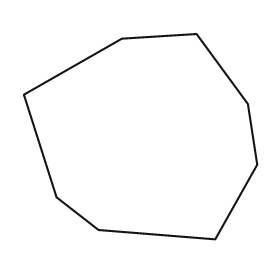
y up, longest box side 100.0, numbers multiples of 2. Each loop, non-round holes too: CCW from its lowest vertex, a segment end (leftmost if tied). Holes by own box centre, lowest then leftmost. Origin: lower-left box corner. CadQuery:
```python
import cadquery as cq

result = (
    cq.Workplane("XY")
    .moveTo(82.0, 0.0)
    .lineTo(100.0, 32.0)
    .lineTo(96.0, 58.0)
    .lineTo(74.0, 88.0)
    .lineTo(42.0, 86.0)
    .lineTo(0.0, 62.0)
    .lineTo(14.0, 18.0)
    .lineTo(32.0, 4.0)
    .close()
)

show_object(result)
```